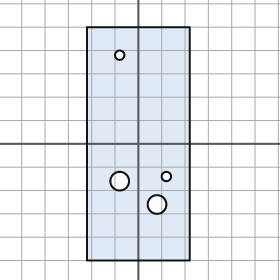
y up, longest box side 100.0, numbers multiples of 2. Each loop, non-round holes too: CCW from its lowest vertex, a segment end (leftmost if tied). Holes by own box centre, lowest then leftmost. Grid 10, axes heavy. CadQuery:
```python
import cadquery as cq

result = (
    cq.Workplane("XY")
    .moveTo(-22.0, -50.0)
    .lineTo(22.0, -50.0)
    .lineTo(22.0, 50.0)
    .lineTo(-22.0, 50.0)
    .close()
    .moveTo(8.0, -26.0)
    .circle(4.0)
    .moveTo(-8.0, -16.0)
    .circle(4.0)
    .moveTo(12.0, -14.0)
    .circle(2.0)
    .moveTo(-8.0, 38.0)
    .circle(2.0)
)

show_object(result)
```